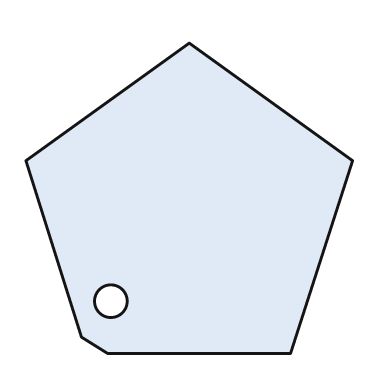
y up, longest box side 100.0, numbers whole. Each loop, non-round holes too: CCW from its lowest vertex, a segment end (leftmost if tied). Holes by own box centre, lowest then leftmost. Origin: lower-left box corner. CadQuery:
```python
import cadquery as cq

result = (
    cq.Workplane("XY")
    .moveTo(25.0, 0.0)
    .lineTo(81.0, 0.0)
    .lineTo(100.0, 59.0)
    .lineTo(50.0, 95.0)
    .lineTo(0.0, 59.0)
    .lineTo(17.0, 5.0)
    .close()
    .moveTo(26.0, 16.0)
    .circle(5.0)
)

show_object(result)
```